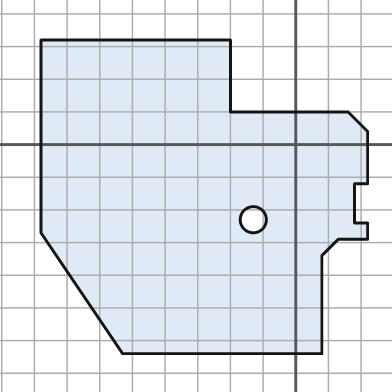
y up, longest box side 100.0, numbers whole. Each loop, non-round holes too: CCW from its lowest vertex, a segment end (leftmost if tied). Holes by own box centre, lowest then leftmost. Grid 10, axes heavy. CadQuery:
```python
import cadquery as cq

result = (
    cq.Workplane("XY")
    .moveTo(-53.0, -64.0)
    .lineTo(8.0, -64.0)
    .lineTo(8.0, -34.0)
    .lineTo(13.0, -29.0)
    .lineTo(22.0, -29.0)
    .lineTo(22.0, -24.0)
    .lineTo(18.0, -24.0)
    .lineTo(18.0, -12.0)
    .lineTo(22.0, -12.0)
    .lineTo(22.0, 4.0)
    .lineTo(16.0, 10.0)
    .lineTo(-20.0, 10.0)
    .lineTo(-20.0, 32.0)
    .lineTo(-78.0, 32.0)
    .lineTo(-78.0, -27.0)
    .close()
    .moveTo(-13.0, -23.0)
    .circle(4.0)
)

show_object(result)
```